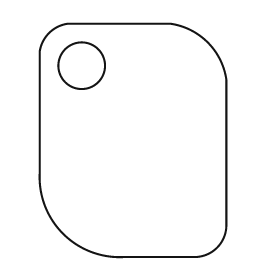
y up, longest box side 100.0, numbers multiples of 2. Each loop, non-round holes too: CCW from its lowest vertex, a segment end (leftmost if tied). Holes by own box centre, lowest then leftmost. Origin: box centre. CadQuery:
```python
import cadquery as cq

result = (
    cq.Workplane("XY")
    .moveTo(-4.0, -50.0)
    .lineTo(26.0, -50.0)
    .threePointArc((36.0, -46.0), (40.0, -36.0))
    .lineTo(40.0, 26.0)
    .threePointArc((32.0, 42.0), (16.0, 50.0))
    .lineTo(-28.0, 50.0)
    .threePointArc((-36.0, 46.0), (-40.0, 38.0))
    .lineTo(-40.0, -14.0)
    .threePointArc((-30.0, -40.0), (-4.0, -50.0))
    .close()
    .moveTo(-22.0, 32.0)
    .circle(10.0)
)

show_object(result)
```